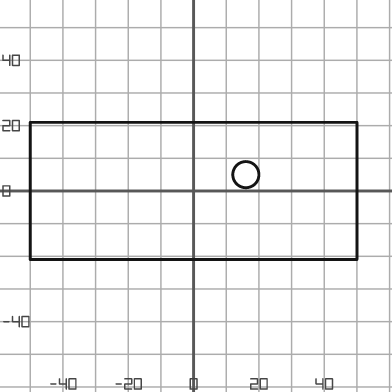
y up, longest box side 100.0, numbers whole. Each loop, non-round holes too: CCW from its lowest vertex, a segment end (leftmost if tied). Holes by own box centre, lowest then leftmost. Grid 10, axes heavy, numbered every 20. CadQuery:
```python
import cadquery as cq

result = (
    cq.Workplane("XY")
    .moveTo(-50.0, -21.0)
    .lineTo(50.0, -21.0)
    .lineTo(50.0, 21.0)
    .lineTo(-50.0, 21.0)
    .close()
    .moveTo(16.0, 5.0)
    .circle(4.0)
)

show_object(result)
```